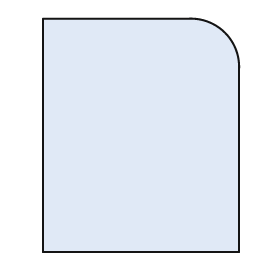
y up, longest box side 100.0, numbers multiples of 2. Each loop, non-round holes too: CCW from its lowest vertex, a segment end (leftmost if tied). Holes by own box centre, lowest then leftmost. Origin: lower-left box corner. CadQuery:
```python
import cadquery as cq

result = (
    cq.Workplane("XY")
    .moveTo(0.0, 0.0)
    .lineTo(84.0, 0.0)
    .lineTo(84.0, 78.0)
    .threePointArc((78.0, 94.0), (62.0, 100.0))
    .lineTo(0.0, 100.0)
    .close()
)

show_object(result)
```